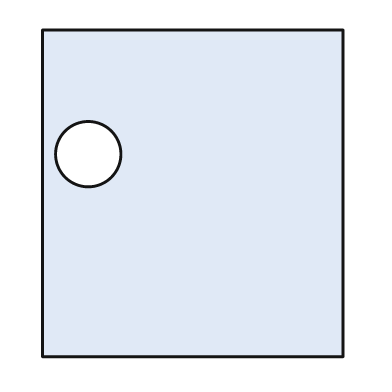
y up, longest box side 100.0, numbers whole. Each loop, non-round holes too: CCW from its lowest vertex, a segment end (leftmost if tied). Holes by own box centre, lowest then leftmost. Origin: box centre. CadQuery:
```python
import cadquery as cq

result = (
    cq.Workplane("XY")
    .moveTo(-46.0, -50.0)
    .lineTo(46.0, -50.0)
    .lineTo(46.0, 50.0)
    .lineTo(-46.0, 50.0)
    .close()
    .moveTo(-32.0, 12.0)
    .circle(10.0)
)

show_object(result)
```